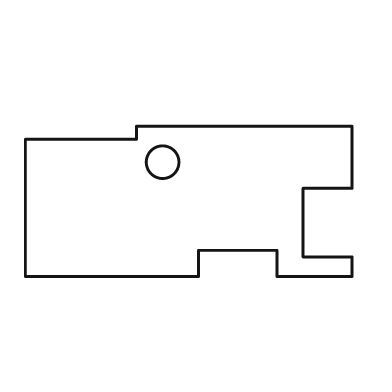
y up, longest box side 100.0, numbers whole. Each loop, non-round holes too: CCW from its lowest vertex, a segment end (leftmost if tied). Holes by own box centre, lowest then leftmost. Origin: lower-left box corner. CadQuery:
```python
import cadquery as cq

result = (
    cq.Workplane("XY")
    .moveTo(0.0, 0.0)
    .lineTo(53.0, 0.0)
    .lineTo(53.0, 8.0)
    .lineTo(77.0, 8.0)
    .lineTo(77.0, 0.0)
    .lineTo(100.0, 0.0)
    .lineTo(100.0, 6.0)
    .lineTo(85.0, 6.0)
    .lineTo(85.0, 27.0)
    .lineTo(100.0, 27.0)
    .lineTo(100.0, 46.0)
    .lineTo(34.0, 46.0)
    .lineTo(34.0, 42.0)
    .lineTo(0.0, 42.0)
    .close()
    .moveTo(42.0, 35.0)
    .circle(5.0)
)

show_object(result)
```